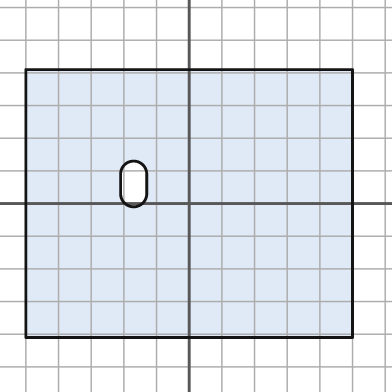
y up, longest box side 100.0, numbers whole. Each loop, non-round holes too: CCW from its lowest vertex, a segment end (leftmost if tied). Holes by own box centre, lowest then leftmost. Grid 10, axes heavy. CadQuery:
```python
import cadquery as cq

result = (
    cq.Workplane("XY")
    .moveTo(-50.0, -41.0)
    .lineTo(50.0, -41.0)
    .lineTo(50.0, 41.0)
    .lineTo(-50.0, 41.0)
    .close()
    .moveTo(-21.0, 3.0)
    .threePointArc((-17.0, -1.0), (-13.0, 3.0))
    .lineTo(-13.0, 9.0)
    .threePointArc((-17.0, 13.0), (-21.0, 9.0))
    .close()
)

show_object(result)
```